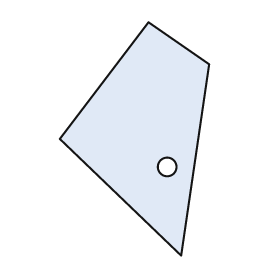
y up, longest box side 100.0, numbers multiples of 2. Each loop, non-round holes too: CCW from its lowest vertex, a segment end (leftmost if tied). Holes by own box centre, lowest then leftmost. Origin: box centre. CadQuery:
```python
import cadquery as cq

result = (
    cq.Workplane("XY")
    .moveTo(20.0, -50.0)
    .lineTo(32.0, 32.0)
    .lineTo(6.0, 50.0)
    .lineTo(-32.0, 0.0)
    .close()
    .moveTo(14.0, -12.0)
    .circle(4.0)
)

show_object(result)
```